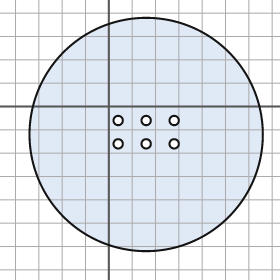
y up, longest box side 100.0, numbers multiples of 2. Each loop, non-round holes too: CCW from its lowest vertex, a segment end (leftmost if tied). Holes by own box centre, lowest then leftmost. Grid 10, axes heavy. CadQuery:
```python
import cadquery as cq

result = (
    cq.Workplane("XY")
    .moveTo(16.0, -12.0)
    .circle(50.0)
    .moveTo(4.0, -16.0)
    .circle(2.0)
    .moveTo(16.0, -16.0)
    .circle(2.0)
    .moveTo(28.0, -16.0)
    .circle(2.0)
    .moveTo(4.0, -6.0)
    .circle(2.0)
    .moveTo(16.0, -6.0)
    .circle(2.0)
    .moveTo(28.0, -6.0)
    .circle(2.0)
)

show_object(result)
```